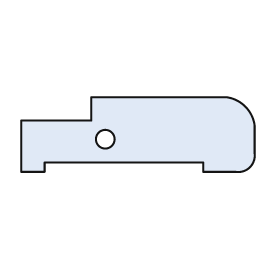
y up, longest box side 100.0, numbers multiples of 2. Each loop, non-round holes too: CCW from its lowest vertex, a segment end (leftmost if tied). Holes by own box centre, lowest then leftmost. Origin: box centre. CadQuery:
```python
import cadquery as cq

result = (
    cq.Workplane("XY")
    .moveTo(-50.0, -16.0)
    .lineTo(-40.0, -16.0)
    .lineTo(-40.0, -12.0)
    .lineTo(28.0, -12.0)
    .lineTo(28.0, -16.0)
    .lineTo(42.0, -16.0)
    .threePointArc((48.0, -14.0), (50.0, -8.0))
    .lineTo(50.0, 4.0)
    .threePointArc((46.0, 12.0), (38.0, 16.0))
    .lineTo(-20.0, 16.0)
    .lineTo(-20.0, 6.0)
    .lineTo(-50.0, 6.0)
    .close()
    .moveTo(-14.0, -2.0)
    .circle(4.0)
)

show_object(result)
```